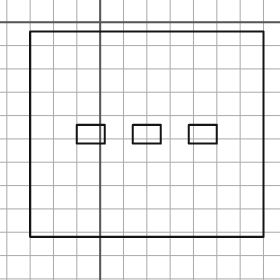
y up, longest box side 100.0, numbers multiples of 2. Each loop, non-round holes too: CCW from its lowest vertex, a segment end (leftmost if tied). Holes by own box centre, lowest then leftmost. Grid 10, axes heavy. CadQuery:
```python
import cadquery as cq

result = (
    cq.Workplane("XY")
    .moveTo(-30.0, -92.0)
    .lineTo(70.0, -92.0)
    .lineTo(70.0, -4.0)
    .lineTo(-30.0, -4.0)
    .close()
    .moveTo(-10.0, -52.0)
    .lineTo(2.0, -52.0)
    .lineTo(2.0, -44.0)
    .lineTo(-10.0, -44.0)
    .close()
    .moveTo(14.0, -52.0)
    .lineTo(26.0, -52.0)
    .lineTo(26.0, -44.0)
    .lineTo(14.0, -44.0)
    .close()
    .moveTo(38.0, -52.0)
    .lineTo(50.0, -52.0)
    .lineTo(50.0, -44.0)
    .lineTo(38.0, -44.0)
    .close()
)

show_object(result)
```